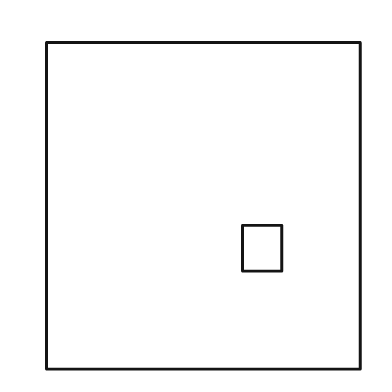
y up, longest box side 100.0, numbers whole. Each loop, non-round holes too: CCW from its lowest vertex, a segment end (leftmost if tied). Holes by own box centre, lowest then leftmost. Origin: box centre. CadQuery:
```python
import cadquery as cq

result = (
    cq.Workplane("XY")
    .moveTo(-48.0, -50.0)
    .lineTo(48.0, -50.0)
    .lineTo(48.0, 50.0)
    .lineTo(-48.0, 50.0)
    .close()
    .moveTo(12.0, -20.0)
    .lineTo(24.0, -20.0)
    .lineTo(24.0, -6.0)
    .lineTo(12.0, -6.0)
    .close()
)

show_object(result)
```